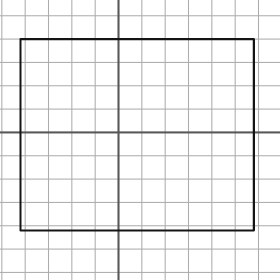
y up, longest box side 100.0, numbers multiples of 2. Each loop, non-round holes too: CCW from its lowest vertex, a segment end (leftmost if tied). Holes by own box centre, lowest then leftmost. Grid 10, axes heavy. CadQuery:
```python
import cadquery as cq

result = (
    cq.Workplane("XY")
    .moveTo(-42.0, -42.0)
    .lineTo(58.0, -42.0)
    .lineTo(58.0, 40.0)
    .lineTo(-42.0, 40.0)
    .close()
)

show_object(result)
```